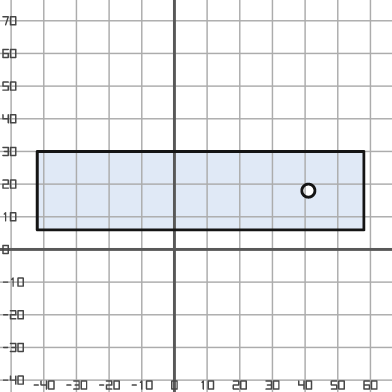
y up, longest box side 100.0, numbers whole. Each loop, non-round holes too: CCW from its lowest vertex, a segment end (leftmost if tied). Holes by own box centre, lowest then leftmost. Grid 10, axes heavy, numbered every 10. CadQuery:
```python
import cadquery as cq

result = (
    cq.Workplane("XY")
    .moveTo(-42.0, 6.0)
    .lineTo(58.0, 6.0)
    .lineTo(58.0, 30.0)
    .lineTo(-42.0, 30.0)
    .close()
    .moveTo(41.0, 18.0)
    .circle(2.0)
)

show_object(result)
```